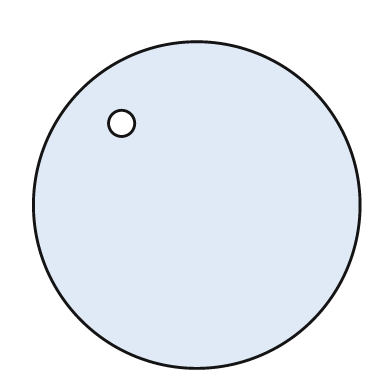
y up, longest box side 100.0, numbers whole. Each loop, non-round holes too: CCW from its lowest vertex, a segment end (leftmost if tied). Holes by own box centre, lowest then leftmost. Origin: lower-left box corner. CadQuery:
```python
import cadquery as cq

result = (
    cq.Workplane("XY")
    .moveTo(50.0, 50.0)
    .circle(50.0)
    .moveTo(27.0, 75.0)
    .circle(4.0)
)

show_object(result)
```